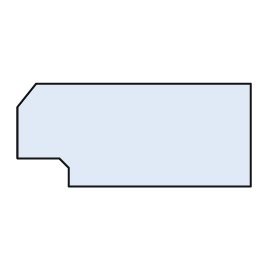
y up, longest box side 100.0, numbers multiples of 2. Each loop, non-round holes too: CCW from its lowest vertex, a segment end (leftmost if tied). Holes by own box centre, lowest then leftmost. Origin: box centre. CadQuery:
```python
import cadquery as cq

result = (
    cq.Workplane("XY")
    .moveTo(-28.0, -22.0)
    .lineTo(50.0, -22.0)
    .lineTo(50.0, 22.0)
    .lineTo(-42.0, 22.0)
    .lineTo(-50.0, 12.0)
    .lineTo(-50.0, -10.0)
    .lineTo(-32.0, -10.0)
    .lineTo(-28.0, -14.0)
    .close()
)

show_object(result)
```